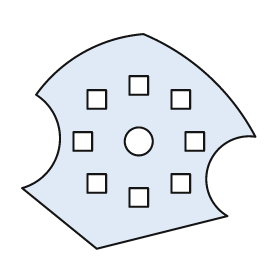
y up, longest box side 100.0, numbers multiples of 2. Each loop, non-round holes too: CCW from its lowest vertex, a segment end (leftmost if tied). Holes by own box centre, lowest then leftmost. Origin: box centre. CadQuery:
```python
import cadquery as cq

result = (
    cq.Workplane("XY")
    .moveTo(-18.0, -46.0)
    .lineTo(38.0, -32.0)
    .threePointArc((30.0, -10.0), (50.0, 2.0))
    .threePointArc((30.0, 28.0), (2.0, 46.0))
    .threePointArc((-24.0, 38.0), (-44.0, 20.0))
    .threePointArc((-34.0, -2.0), (-50.0, -20.0))
    .close()
    .moveTo(-4.0, -28.0)
    .lineTo(4.0, -28.0)
    .lineTo(4.0, -20.0)
    .lineTo(-4.0, -20.0)
    .close()
    .moveTo(-22.0, -22.0)
    .lineTo(-14.0, -22.0)
    .lineTo(-14.0, -14.0)
    .lineTo(-22.0, -14.0)
    .close()
    .moveTo(14.0, -22.0)
    .lineTo(22.0, -22.0)
    .lineTo(22.0, -14.0)
    .lineTo(14.0, -14.0)
    .close()
    .moveTo(-28.0, -4.0)
    .lineTo(-20.0, -4.0)
    .lineTo(-20.0, 4.0)
    .lineTo(-28.0, 4.0)
    .close()
    .moveTo(0.0, 0.0)
    .circle(6.0)
    .moveTo(20.0, -4.0)
    .lineTo(28.0, -4.0)
    .lineTo(28.0, 4.0)
    .lineTo(20.0, 4.0)
    .close()
    .moveTo(-22.0, 14.0)
    .lineTo(-14.0, 14.0)
    .lineTo(-14.0, 22.0)
    .lineTo(-22.0, 22.0)
    .close()
    .moveTo(14.0, 14.0)
    .lineTo(22.0, 14.0)
    .lineTo(22.0, 22.0)
    .lineTo(14.0, 22.0)
    .close()
    .moveTo(-4.0, 20.0)
    .lineTo(4.0, 20.0)
    .lineTo(4.0, 28.0)
    .lineTo(-4.0, 28.0)
    .close()
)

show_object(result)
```